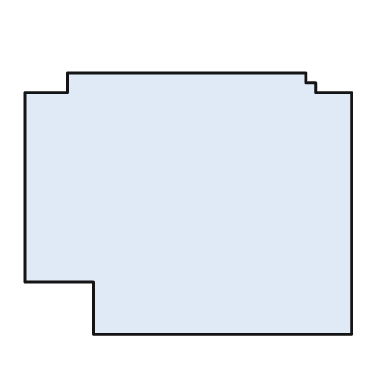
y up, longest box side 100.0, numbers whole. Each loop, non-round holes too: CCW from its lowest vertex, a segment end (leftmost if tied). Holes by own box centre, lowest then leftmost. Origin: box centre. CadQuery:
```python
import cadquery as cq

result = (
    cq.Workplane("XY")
    .moveTo(-29.0, -40.0)
    .lineTo(50.0, -40.0)
    .lineTo(50.0, 34.0)
    .lineTo(39.0, 34.0)
    .lineTo(39.0, 37.0)
    .lineTo(36.0, 37.0)
    .lineTo(36.0, 40.0)
    .lineTo(-37.0, 40.0)
    .lineTo(-37.0, 34.0)
    .lineTo(-50.0, 34.0)
    .lineTo(-50.0, -24.0)
    .lineTo(-29.0, -24.0)
    .close()
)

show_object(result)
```